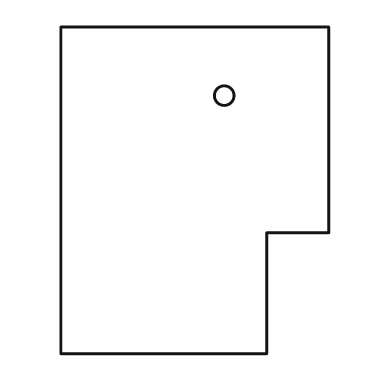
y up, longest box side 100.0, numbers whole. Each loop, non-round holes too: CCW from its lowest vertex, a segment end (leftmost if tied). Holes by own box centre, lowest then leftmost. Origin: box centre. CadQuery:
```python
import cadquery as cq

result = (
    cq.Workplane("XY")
    .moveTo(-41.0, -50.0)
    .lineTo(22.0, -50.0)
    .lineTo(22.0, -13.0)
    .lineTo(41.0, -13.0)
    .lineTo(41.0, 50.0)
    .lineTo(-41.0, 50.0)
    .close()
    .moveTo(9.0, 29.0)
    .circle(3.0)
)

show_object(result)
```